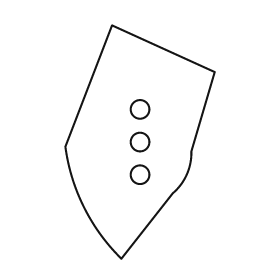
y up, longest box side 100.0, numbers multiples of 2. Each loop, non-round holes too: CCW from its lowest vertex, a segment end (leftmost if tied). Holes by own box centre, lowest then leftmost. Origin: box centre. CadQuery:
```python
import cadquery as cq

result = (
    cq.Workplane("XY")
    .moveTo(-8.0, -50.0)
    .lineTo(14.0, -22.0)
    .threePointArc((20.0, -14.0), (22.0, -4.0))
    .lineTo(32.0, 30.0)
    .lineTo(-12.0, 50.0)
    .lineTo(-32.0, -2.0)
    .threePointArc((-24.0, -28.0), (-8.0, -50.0))
    .close()
    .moveTo(0.0, -14.0)
    .circle(4.0)
    .moveTo(0.0, 0.0)
    .circle(4.0)
    .moveTo(0.0, 14.0)
    .circle(4.0)
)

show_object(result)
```